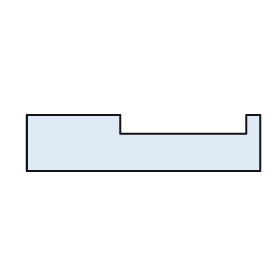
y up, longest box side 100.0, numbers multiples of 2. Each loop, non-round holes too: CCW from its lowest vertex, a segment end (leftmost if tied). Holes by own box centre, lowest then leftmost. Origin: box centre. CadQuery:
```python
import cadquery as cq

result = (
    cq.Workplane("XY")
    .moveTo(-50.0, -12.0)
    .lineTo(50.0, -12.0)
    .lineTo(50.0, 12.0)
    .lineTo(44.0, 12.0)
    .lineTo(44.0, 4.0)
    .lineTo(-10.0, 4.0)
    .lineTo(-10.0, 12.0)
    .lineTo(-50.0, 12.0)
    .close()
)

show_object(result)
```